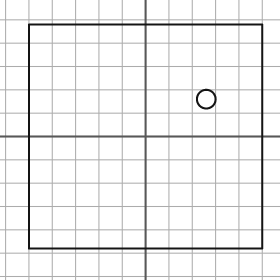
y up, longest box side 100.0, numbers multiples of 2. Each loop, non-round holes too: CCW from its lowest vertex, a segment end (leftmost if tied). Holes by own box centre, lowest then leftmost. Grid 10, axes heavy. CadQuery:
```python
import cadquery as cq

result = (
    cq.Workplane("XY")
    .moveTo(-50.0, -48.0)
    .lineTo(50.0, -48.0)
    .lineTo(50.0, 48.0)
    .lineTo(-50.0, 48.0)
    .close()
    .moveTo(26.0, 16.0)
    .circle(4.0)
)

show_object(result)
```